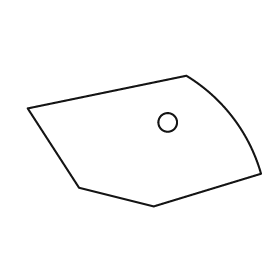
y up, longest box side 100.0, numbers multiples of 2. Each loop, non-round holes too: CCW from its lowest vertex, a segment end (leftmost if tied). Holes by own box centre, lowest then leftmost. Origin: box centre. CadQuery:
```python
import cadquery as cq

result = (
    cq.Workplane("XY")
    .moveTo(4.0, -28.0)
    .lineTo(50.0, -14.0)
    .threePointArc((38.0, 10.0), (18.0, 28.0))
    .lineTo(-50.0, 14.0)
    .lineTo(-28.0, -20.0)
    .close()
    .moveTo(10.0, 8.0)
    .circle(4.0)
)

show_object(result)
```